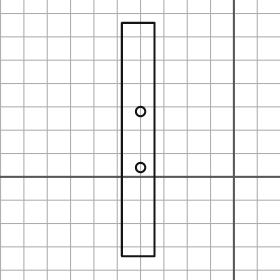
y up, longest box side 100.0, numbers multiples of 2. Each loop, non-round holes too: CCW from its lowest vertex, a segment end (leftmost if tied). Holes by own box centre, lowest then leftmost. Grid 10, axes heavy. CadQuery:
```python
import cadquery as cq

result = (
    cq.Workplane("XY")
    .moveTo(-48.0, -34.0)
    .lineTo(-34.0, -34.0)
    .lineTo(-34.0, 66.0)
    .lineTo(-48.0, 66.0)
    .close()
    .moveTo(-40.0, 4.0)
    .circle(2.0)
    .moveTo(-40.0, 28.0)
    .circle(2.0)
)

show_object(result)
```